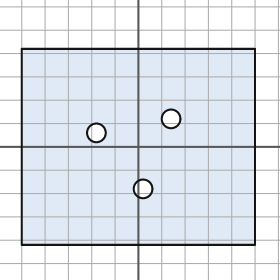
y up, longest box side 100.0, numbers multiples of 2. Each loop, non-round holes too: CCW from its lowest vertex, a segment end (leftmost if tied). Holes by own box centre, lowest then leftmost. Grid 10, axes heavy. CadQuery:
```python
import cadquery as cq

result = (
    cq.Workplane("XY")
    .moveTo(-50.0, -42.0)
    .lineTo(50.0, -42.0)
    .lineTo(50.0, 42.0)
    .lineTo(-50.0, 42.0)
    .close()
    .moveTo(2.0, -18.0)
    .circle(4.0)
    .moveTo(-18.0, 6.0)
    .circle(4.0)
    .moveTo(14.0, 12.0)
    .circle(4.0)
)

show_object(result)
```